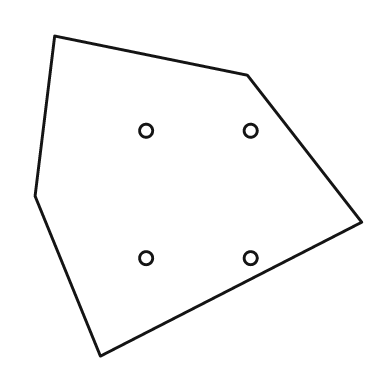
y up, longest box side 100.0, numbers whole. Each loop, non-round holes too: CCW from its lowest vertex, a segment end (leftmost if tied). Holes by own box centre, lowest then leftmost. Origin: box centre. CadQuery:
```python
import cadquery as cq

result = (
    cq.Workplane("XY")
    .moveTo(-30.0, -49.0)
    .lineTo(50.0, -8.0)
    .lineTo(15.0, 37.0)
    .lineTo(-44.0, 49.0)
    .lineTo(-50.0, 0.0)
    .close()
    .moveTo(-16.0, -19.0)
    .circle(2.0)
    .moveTo(16.0, -19.0)
    .circle(2.0)
    .moveTo(-16.0, 20.0)
    .circle(2.0)
    .moveTo(16.0, 20.0)
    .circle(2.0)
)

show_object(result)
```